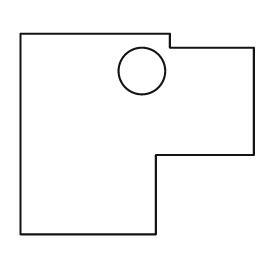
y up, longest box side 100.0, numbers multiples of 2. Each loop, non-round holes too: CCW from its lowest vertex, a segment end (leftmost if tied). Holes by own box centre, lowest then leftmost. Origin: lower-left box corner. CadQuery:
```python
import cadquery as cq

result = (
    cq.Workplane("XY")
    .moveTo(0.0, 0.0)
    .lineTo(58.0, 0.0)
    .lineTo(58.0, 34.0)
    .lineTo(100.0, 34.0)
    .lineTo(100.0, 80.0)
    .lineTo(64.0, 80.0)
    .lineTo(64.0, 86.0)
    .lineTo(0.0, 86.0)
    .close()
    .moveTo(52.0, 70.0)
    .circle(10.0)
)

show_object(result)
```